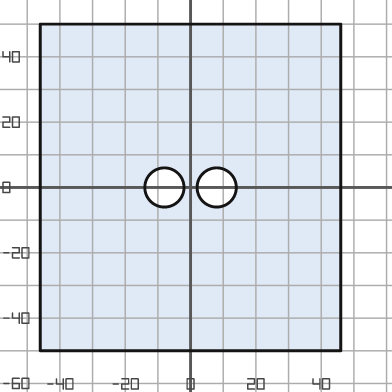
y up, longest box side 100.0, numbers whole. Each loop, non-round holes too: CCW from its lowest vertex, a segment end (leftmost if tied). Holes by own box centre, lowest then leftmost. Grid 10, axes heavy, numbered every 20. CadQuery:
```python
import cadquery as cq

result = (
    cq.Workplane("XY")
    .moveTo(-46.0, -50.0)
    .lineTo(46.0, -50.0)
    .lineTo(46.0, 50.0)
    .lineTo(-46.0, 50.0)
    .close()
    .moveTo(-8.0, 0.0)
    .circle(6.0)
    .moveTo(8.0, 0.0)
    .circle(6.0)
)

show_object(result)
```